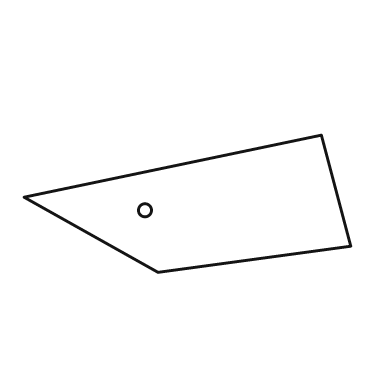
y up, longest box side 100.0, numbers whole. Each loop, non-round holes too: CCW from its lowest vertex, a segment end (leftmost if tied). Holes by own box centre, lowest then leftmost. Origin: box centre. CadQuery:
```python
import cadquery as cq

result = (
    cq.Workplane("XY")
    .moveTo(-9.0, -21.0)
    .lineTo(50.0, -13.0)
    .lineTo(41.0, 21.0)
    .lineTo(-50.0, 2.0)
    .close()
    .moveTo(-13.0, -2.0)
    .circle(2.0)
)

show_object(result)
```